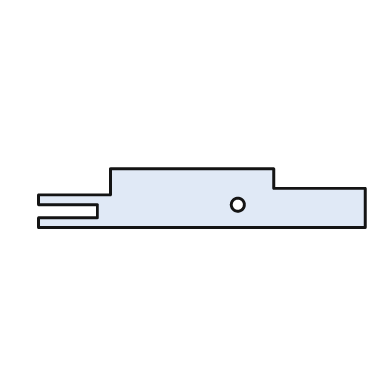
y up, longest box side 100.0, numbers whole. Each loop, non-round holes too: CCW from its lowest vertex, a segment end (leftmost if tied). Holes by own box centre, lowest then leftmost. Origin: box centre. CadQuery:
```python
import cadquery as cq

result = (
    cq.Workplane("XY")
    .moveTo(-50.0, -9.0)
    .lineTo(50.0, -9.0)
    .lineTo(50.0, 3.0)
    .lineTo(22.0, 3.0)
    .lineTo(22.0, 9.0)
    .lineTo(-28.0, 9.0)
    .lineTo(-28.0, 1.0)
    .lineTo(-50.0, 1.0)
    .lineTo(-50.0, -2.0)
    .lineTo(-32.0, -2.0)
    .lineTo(-32.0, -6.0)
    .lineTo(-50.0, -6.0)
    .close()
    .moveTo(11.0, -2.0)
    .circle(2.0)
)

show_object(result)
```